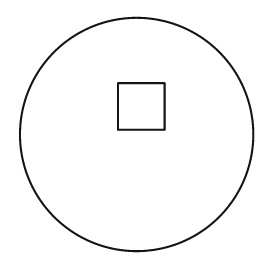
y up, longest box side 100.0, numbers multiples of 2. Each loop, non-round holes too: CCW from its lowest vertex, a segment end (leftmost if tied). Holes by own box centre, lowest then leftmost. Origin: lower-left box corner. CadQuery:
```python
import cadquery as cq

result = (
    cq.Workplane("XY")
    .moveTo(50.0, 50.0)
    .circle(50.0)
    .moveTo(42.0, 52.0)
    .lineTo(62.0, 52.0)
    .lineTo(62.0, 72.0)
    .lineTo(42.0, 72.0)
    .close()
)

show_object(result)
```